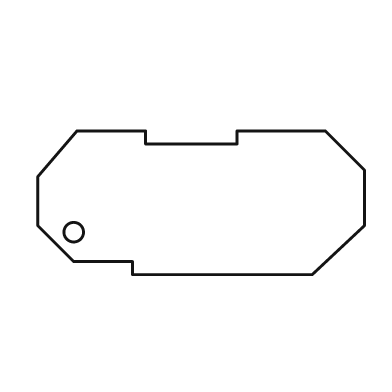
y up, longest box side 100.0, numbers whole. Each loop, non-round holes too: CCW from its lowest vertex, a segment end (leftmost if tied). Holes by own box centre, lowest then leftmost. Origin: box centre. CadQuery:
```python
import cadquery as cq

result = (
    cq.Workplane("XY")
    .moveTo(-21.0, -22.0)
    .lineTo(34.0, -22.0)
    .lineTo(50.0, -7.0)
    .lineTo(50.0, 10.0)
    .lineTo(38.0, 22.0)
    .lineTo(11.0, 22.0)
    .lineTo(11.0, 18.0)
    .lineTo(-17.0, 18.0)
    .lineTo(-17.0, 22.0)
    .lineTo(-38.0, 22.0)
    .lineTo(-50.0, 8.0)
    .lineTo(-50.0, -7.0)
    .lineTo(-39.0, -18.0)
    .lineTo(-21.0, -18.0)
    .close()
    .moveTo(-39.0, -9.0)
    .circle(3.0)
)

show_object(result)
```